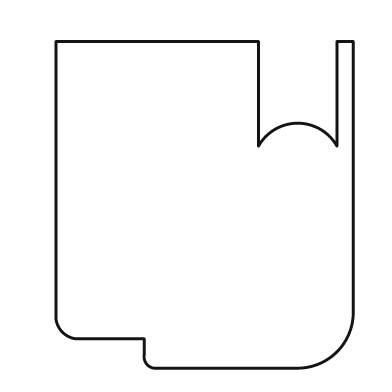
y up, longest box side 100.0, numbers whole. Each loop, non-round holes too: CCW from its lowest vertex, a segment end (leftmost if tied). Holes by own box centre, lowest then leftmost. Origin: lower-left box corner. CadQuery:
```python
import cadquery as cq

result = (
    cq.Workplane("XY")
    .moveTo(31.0, 0.0)
    .lineTo(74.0, 0.0)
    .threePointArc((86.0, 5.0), (91.0, 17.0))
    .lineTo(91.0, 100.0)
    .lineTo(86.0, 100.0)
    .lineTo(86.0, 68.0)
    .threePointArc((74.0, 75.0), (62.0, 68.0))
    .lineTo(62.0, 100.0)
    .lineTo(0.0, 100.0)
    .lineTo(0.0, 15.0)
    .threePointArc((2.0, 11.0), (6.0, 9.0))
    .lineTo(27.0, 9.0)
    .lineTo(27.0, 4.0)
    .threePointArc((28.0, 1.0), (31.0, 0.0))
    .close()
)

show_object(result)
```